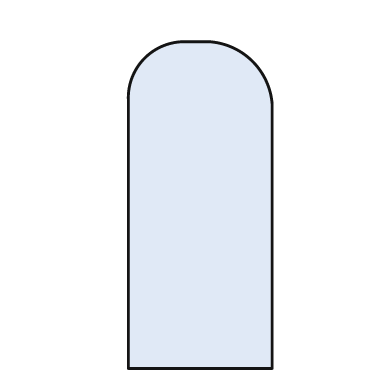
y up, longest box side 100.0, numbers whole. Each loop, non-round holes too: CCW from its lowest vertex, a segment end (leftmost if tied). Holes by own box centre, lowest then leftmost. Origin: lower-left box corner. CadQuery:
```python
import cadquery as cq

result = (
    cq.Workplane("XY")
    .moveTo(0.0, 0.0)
    .lineTo(44.0, 0.0)
    .lineTo(44.0, 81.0)
    .threePointArc((38.0, 94.0), (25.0, 100.0))
    .lineTo(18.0, 100.0)
    .threePointArc((5.0, 95.0), (0.0, 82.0))
    .close()
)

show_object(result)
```